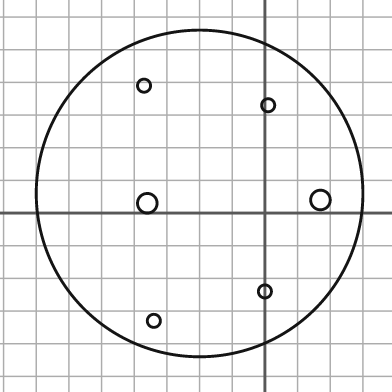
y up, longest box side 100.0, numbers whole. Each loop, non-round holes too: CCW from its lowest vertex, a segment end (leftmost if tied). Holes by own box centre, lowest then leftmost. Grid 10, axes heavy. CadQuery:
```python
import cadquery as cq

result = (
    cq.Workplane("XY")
    .moveTo(-20.0, 6.0)
    .circle(50.0)
    .moveTo(-34.0, -33.0)
    .circle(2.0)
    .moveTo(0.0, -24.0)
    .circle(2.0)
    .moveTo(-36.0, 3.0)
    .circle(3.0)
    .moveTo(17.0, 4.0)
    .circle(3.0)
    .moveTo(1.0, 33.0)
    .circle(2.0)
    .moveTo(-37.0, 39.0)
    .circle(2.0)
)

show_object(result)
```